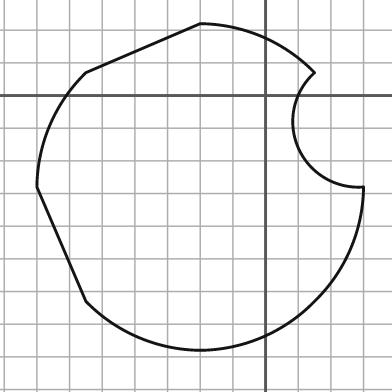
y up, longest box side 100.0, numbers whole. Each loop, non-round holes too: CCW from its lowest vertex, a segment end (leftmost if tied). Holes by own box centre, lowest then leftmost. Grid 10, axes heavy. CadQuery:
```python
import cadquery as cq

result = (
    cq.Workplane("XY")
    .moveTo(-20.0, -78.0)
    .threePointArc((-1.0, -74.0), (15.0, -63.0))
    .threePointArc((26.0, -47.0), (30.0, -28.0))
    .threePointArc((10.0, -16.0), (15.0, 7.0))
    .threePointArc((-1.0, 18.0), (-20.0, 22.0))
    .lineTo(-55.0, 7.0)
    .threePointArc((-66.0, -9.0), (-70.0, -28.0))
    .lineTo(-55.0, -63.0)
    .threePointArc((-39.0, -74.0), (-20.0, -78.0))
    .close()
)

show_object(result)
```